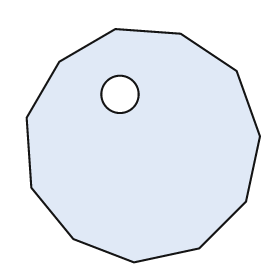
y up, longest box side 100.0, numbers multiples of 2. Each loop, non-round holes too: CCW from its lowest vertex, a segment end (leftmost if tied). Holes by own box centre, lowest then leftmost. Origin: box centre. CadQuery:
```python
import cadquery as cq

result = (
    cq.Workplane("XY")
    .moveTo(-4.0, -50.0)
    .lineTo(24.0, -44.0)
    .lineTo(44.0, -24.0)
    .lineTo(50.0, 4.0)
    .lineTo(40.0, 32.0)
    .lineTo(16.0, 48.0)
    .lineTo(-12.0, 50.0)
    .lineTo(-36.0, 36.0)
    .lineTo(-50.0, 12.0)
    .lineTo(-48.0, -18.0)
    .lineTo(-30.0, -40.0)
    .close()
    .moveTo(-10.0, 22.0)
    .circle(8.0)
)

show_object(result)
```